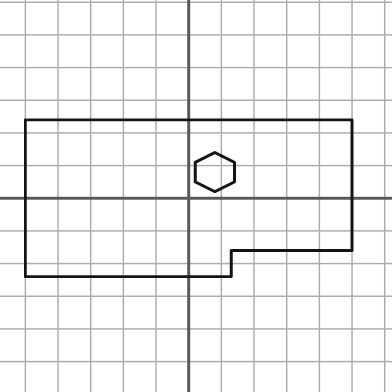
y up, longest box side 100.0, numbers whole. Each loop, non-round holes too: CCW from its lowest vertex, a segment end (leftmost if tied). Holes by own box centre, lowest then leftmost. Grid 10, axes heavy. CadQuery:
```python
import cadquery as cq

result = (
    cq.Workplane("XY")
    .moveTo(-50.0, -24.0)
    .lineTo(13.0, -24.0)
    .lineTo(13.0, -16.0)
    .lineTo(50.0, -16.0)
    .lineTo(50.0, 24.0)
    .lineTo(-50.0, 24.0)
    .close()
    .moveTo(8.0, 2.0)
    .lineTo(14.0, 5.0)
    .lineTo(14.0, 11.0)
    .lineTo(8.0, 14.0)
    .lineTo(2.0, 11.0)
    .lineTo(2.0, 5.0)
    .close()
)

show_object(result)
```